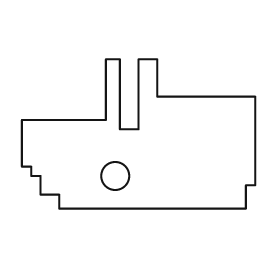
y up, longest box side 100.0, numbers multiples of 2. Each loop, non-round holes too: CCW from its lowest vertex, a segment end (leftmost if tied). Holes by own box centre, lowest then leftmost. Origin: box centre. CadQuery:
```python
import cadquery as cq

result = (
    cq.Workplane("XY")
    .moveTo(-34.0, -32.0)
    .lineTo(46.0, -32.0)
    .lineTo(46.0, -22.0)
    .lineTo(50.0, -22.0)
    .lineTo(50.0, 16.0)
    .lineTo(8.0, 16.0)
    .lineTo(8.0, 32.0)
    .lineTo(0.0, 32.0)
    .lineTo(0.0, 2.0)
    .lineTo(-8.0, 2.0)
    .lineTo(-8.0, 32.0)
    .lineTo(-14.0, 32.0)
    .lineTo(-14.0, 6.0)
    .lineTo(-50.0, 6.0)
    .lineTo(-50.0, -14.0)
    .lineTo(-46.0, -14.0)
    .lineTo(-46.0, -18.0)
    .lineTo(-42.0, -18.0)
    .lineTo(-42.0, -26.0)
    .lineTo(-34.0, -26.0)
    .close()
    .moveTo(-10.0, -18.0)
    .circle(6.0)
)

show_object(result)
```